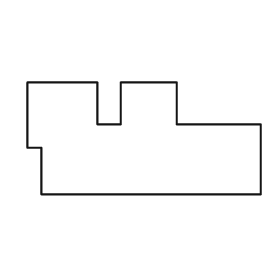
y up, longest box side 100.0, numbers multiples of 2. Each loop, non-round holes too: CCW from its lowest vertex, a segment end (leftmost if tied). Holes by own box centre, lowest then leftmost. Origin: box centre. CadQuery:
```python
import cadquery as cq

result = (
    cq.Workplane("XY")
    .moveTo(-44.0, -24.0)
    .lineTo(50.0, -24.0)
    .lineTo(50.0, 6.0)
    .lineTo(14.0, 6.0)
    .lineTo(14.0, 24.0)
    .lineTo(-10.0, 24.0)
    .lineTo(-10.0, 6.0)
    .lineTo(-20.0, 6.0)
    .lineTo(-20.0, 24.0)
    .lineTo(-50.0, 24.0)
    .lineTo(-50.0, -4.0)
    .lineTo(-44.0, -4.0)
    .close()
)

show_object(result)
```